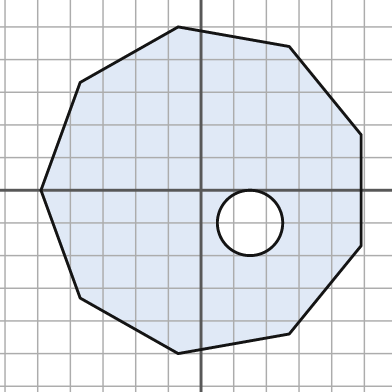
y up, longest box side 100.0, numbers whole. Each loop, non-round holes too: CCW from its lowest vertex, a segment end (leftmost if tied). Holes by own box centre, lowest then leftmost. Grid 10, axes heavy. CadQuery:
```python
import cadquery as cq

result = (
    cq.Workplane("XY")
    .moveTo(-7.0, -50.0)
    .lineTo(27.0, -44.0)
    .lineTo(49.0, -17.0)
    .lineTo(49.0, 17.0)
    .lineTo(27.0, 44.0)
    .lineTo(-7.0, 50.0)
    .lineTo(-37.0, 33.0)
    .lineTo(-49.0, 0.0)
    .lineTo(-37.0, -33.0)
    .close()
    .moveTo(15.0, -10.0)
    .circle(10.0)
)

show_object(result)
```